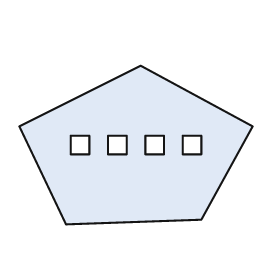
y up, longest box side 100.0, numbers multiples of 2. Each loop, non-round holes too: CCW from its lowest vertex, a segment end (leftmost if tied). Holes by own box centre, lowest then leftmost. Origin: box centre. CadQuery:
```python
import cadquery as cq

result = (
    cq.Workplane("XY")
    .moveTo(-30.0, -34.0)
    .lineTo(28.0, -32.0)
    .lineTo(50.0, 8.0)
    .lineTo(2.0, 34.0)
    .lineTo(-50.0, 8.0)
    .close()
    .moveTo(-28.0, -4.0)
    .lineTo(-20.0, -4.0)
    .lineTo(-20.0, 4.0)
    .lineTo(-28.0, 4.0)
    .close()
    .moveTo(-12.0, -4.0)
    .lineTo(-4.0, -4.0)
    .lineTo(-4.0, 4.0)
    .lineTo(-12.0, 4.0)
    .close()
    .moveTo(4.0, -4.0)
    .lineTo(12.0, -4.0)
    .lineTo(12.0, 4.0)
    .lineTo(4.0, 4.0)
    .close()
    .moveTo(20.0, -4.0)
    .lineTo(28.0, -4.0)
    .lineTo(28.0, 4.0)
    .lineTo(20.0, 4.0)
    .close()
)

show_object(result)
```